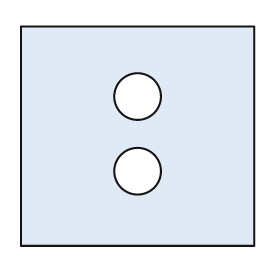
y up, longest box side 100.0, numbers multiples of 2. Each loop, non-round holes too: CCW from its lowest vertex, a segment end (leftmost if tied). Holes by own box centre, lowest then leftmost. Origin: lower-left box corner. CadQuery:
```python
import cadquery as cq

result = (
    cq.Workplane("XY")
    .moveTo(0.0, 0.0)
    .lineTo(100.0, 0.0)
    .lineTo(100.0, 94.0)
    .lineTo(0.0, 94.0)
    .close()
    .moveTo(50.0, 32.0)
    .circle(10.0)
    .moveTo(50.0, 64.0)
    .circle(10.0)
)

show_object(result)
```